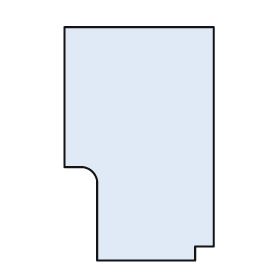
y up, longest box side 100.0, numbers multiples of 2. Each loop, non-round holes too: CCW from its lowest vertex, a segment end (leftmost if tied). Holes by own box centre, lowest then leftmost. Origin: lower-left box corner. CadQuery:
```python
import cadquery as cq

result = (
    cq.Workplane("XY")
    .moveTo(14.0, 0.0)
    .lineTo(56.0, 0.0)
    .lineTo(56.0, 6.0)
    .lineTo(64.0, 6.0)
    .lineTo(64.0, 100.0)
    .lineTo(0.0, 100.0)
    .lineTo(0.0, 40.0)
    .lineTo(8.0, 40.0)
    .threePointArc((12.0, 38.0), (14.0, 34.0))
    .close()
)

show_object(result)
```